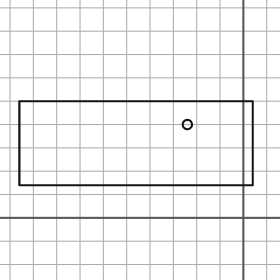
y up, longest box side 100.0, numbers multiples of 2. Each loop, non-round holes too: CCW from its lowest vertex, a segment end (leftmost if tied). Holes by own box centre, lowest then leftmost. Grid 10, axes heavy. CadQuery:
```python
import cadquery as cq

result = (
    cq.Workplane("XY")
    .moveTo(-96.0, 14.0)
    .lineTo(4.0, 14.0)
    .lineTo(4.0, 50.0)
    .lineTo(-96.0, 50.0)
    .close()
    .moveTo(-24.0, 40.0)
    .circle(2.0)
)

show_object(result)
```